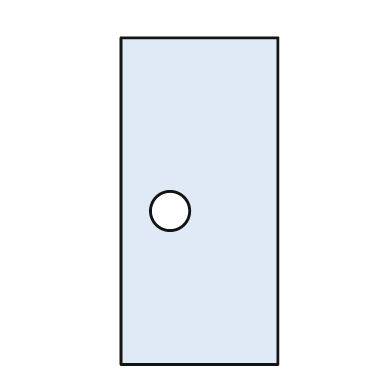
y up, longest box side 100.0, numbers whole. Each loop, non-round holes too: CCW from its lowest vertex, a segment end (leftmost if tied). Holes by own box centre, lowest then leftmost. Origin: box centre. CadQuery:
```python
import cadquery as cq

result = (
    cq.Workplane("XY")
    .moveTo(-24.0, -50.0)
    .lineTo(24.0, -50.0)
    .lineTo(24.0, 50.0)
    .lineTo(-24.0, 50.0)
    .close()
    .moveTo(-9.0, -3.0)
    .circle(6.0)
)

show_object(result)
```